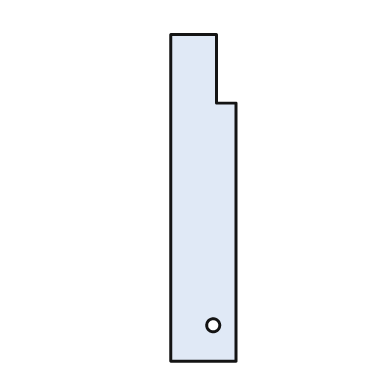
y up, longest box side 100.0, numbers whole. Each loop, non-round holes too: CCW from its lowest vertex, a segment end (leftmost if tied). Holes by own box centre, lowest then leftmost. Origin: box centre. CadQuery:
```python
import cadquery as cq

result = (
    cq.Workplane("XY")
    .moveTo(-10.0, -50.0)
    .lineTo(10.0, -50.0)
    .lineTo(10.0, 29.0)
    .lineTo(4.0, 29.0)
    .lineTo(4.0, 50.0)
    .lineTo(-10.0, 50.0)
    .close()
    .moveTo(3.0, -39.0)
    .circle(2.0)
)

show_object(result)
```